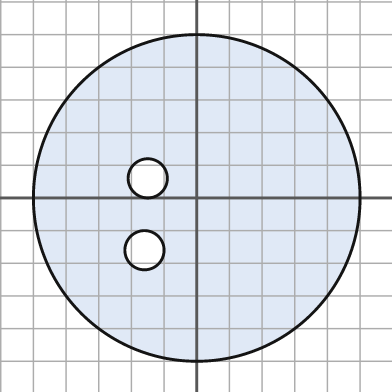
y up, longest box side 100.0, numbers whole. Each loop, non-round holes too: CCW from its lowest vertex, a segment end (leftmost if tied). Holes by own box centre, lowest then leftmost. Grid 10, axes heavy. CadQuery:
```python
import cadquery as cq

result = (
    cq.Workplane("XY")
    .moveTo(0.0, 0.0)
    .circle(50.0)
    .moveTo(-16.0, -16.0)
    .circle(6.0)
    .moveTo(-15.0, 6.0)
    .circle(6.0)
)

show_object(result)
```